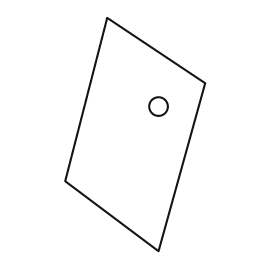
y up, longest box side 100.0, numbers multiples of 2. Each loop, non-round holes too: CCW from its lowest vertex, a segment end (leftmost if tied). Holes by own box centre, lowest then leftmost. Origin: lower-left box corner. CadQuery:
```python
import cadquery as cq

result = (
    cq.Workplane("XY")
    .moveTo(40.0, 0.0)
    .lineTo(60.0, 72.0)
    .lineTo(18.0, 100.0)
    .lineTo(0.0, 30.0)
    .close()
    .moveTo(40.0, 62.0)
    .circle(4.0)
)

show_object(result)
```